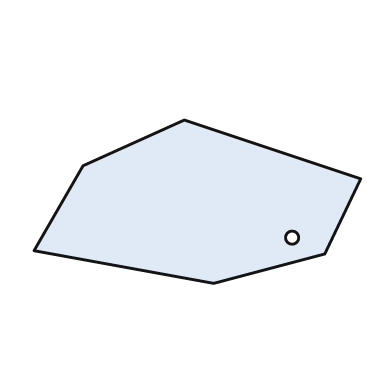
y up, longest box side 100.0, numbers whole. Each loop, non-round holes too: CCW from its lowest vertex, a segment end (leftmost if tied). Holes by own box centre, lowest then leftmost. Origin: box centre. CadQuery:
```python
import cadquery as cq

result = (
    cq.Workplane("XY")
    .moveTo(5.0, -25.0)
    .lineTo(39.0, -16.0)
    .lineTo(50.0, 7.0)
    .lineTo(-4.0, 25.0)
    .lineTo(-35.0, 11.0)
    .lineTo(-50.0, -15.0)
    .close()
    .moveTo(29.0, -11.0)
    .circle(2.0)
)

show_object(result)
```